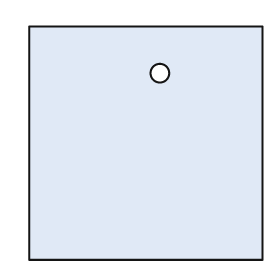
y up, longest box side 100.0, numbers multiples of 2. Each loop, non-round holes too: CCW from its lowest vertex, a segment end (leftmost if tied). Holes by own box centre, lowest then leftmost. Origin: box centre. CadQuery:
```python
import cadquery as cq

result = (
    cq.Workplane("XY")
    .moveTo(-50.0, -50.0)
    .lineTo(50.0, -50.0)
    .lineTo(50.0, 50.0)
    .lineTo(-50.0, 50.0)
    .close()
    .moveTo(6.0, 30.0)
    .circle(4.0)
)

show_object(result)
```